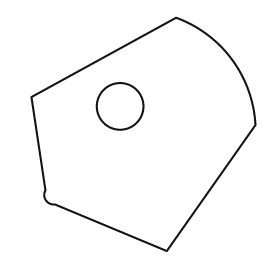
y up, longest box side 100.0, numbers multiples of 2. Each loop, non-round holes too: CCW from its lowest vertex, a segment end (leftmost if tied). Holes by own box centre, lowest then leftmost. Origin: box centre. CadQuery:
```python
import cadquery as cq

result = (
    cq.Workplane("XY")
    .moveTo(10.0, -50.0)
    .lineTo(48.0, 4.0)
    .threePointArc((38.0, 32.0), (14.0, 50.0))
    .lineTo(-48.0, 16.0)
    .lineTo(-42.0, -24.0)
    .threePointArc((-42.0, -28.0), (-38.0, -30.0))
    .close()
    .moveTo(-10.0, 12.0)
    .circle(10.0)
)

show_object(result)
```